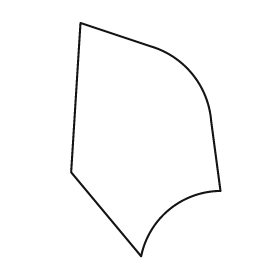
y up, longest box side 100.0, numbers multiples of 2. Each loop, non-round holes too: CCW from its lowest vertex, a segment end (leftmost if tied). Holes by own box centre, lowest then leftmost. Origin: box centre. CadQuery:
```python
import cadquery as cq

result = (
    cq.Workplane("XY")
    .moveTo(-2.0, -50.0)
    .threePointArc((10.0, -30.0), (32.0, -22.0))
    .lineTo(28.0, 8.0)
    .threePointArc((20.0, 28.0), (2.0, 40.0))
    .lineTo(-28.0, 50.0)
    .lineTo(-32.0, -14.0)
    .close()
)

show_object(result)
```